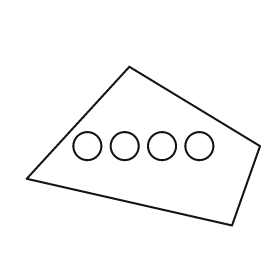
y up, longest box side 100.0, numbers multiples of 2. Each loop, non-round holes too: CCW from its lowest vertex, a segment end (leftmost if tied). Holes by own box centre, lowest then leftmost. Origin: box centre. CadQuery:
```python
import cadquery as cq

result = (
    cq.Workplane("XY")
    .moveTo(38.0, -34.0)
    .lineTo(50.0, 0.0)
    .lineTo(-6.0, 34.0)
    .lineTo(-50.0, -14.0)
    .close()
    .moveTo(-24.0, 0.0)
    .circle(6.0)
    .moveTo(-8.0, 0.0)
    .circle(6.0)
    .moveTo(8.0, 0.0)
    .circle(6.0)
    .moveTo(24.0, 0.0)
    .circle(6.0)
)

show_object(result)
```